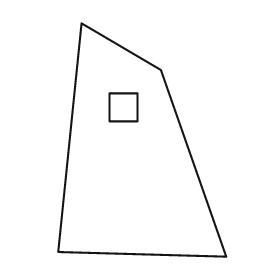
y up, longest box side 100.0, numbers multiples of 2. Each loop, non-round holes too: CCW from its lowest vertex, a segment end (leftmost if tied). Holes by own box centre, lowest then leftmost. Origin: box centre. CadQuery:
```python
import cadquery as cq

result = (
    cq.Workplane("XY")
    .moveTo(36.0, -50.0)
    .lineTo(8.0, 30.0)
    .lineTo(-26.0, 50.0)
    .lineTo(-36.0, -48.0)
    .close()
    .moveTo(-14.0, 8.0)
    .lineTo(-2.0, 8.0)
    .lineTo(-2.0, 20.0)
    .lineTo(-14.0, 20.0)
    .close()
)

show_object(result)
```